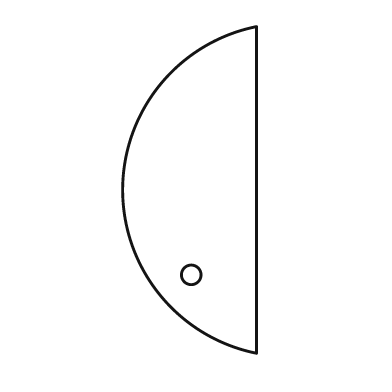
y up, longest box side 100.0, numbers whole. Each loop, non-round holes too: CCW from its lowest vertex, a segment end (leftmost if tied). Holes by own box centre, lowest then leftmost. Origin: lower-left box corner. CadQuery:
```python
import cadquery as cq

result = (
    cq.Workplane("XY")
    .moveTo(41.0, 0.0)
    .lineTo(41.0, 100.0)
    .threePointArc((0.0, 50.0), (41.0, 0.0))
    .close()
    .moveTo(21.0, 24.0)
    .circle(3.0)
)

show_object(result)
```